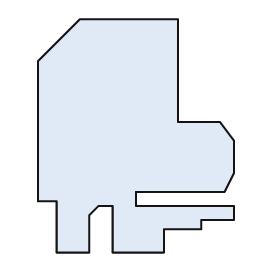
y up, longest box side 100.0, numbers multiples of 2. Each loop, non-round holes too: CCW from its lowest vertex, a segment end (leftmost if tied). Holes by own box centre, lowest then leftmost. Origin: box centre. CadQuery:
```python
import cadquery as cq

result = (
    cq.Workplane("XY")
    .moveTo(-34.0, -50.0)
    .lineTo(-20.0, -50.0)
    .lineTo(-20.0, -34.0)
    .lineTo(-16.0, -30.0)
    .lineTo(-10.0, -30.0)
    .lineTo(-10.0, -50.0)
    .lineTo(12.0, -50.0)
    .lineTo(12.0, -40.0)
    .lineTo(28.0, -40.0)
    .lineTo(28.0, -36.0)
    .lineTo(42.0, -36.0)
    .lineTo(42.0, -30.0)
    .lineTo(0.0, -30.0)
    .lineTo(0.0, -24.0)
    .lineTo(38.0, -24.0)
    .lineTo(42.0, -16.0)
    .lineTo(42.0, -2.0)
    .lineTo(36.0, 6.0)
    .lineTo(18.0, 6.0)
    .lineTo(18.0, 50.0)
    .lineTo(-24.0, 50.0)
    .lineTo(-42.0, 32.0)
    .lineTo(-42.0, -28.0)
    .lineTo(-34.0, -28.0)
    .close()
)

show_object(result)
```